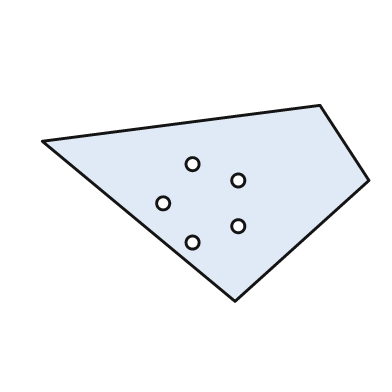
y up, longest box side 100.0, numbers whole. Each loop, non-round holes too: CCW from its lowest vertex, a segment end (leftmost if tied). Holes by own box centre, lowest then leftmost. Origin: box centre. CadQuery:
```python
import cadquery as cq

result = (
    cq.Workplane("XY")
    .moveTo(9.0, -30.0)
    .lineTo(50.0, 7.0)
    .lineTo(35.0, 30.0)
    .lineTo(-50.0, 19.0)
    .close()
    .moveTo(-4.0, -12.0)
    .circle(2.0)
    .moveTo(10.0, -7.0)
    .circle(2.0)
    .moveTo(-13.0, 0.0)
    .circle(2.0)
    .moveTo(10.0, 7.0)
    .circle(2.0)
    .moveTo(-4.0, 12.0)
    .circle(2.0)
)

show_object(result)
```